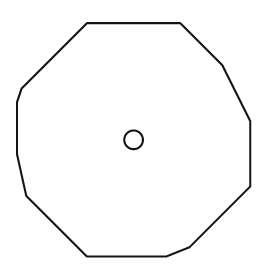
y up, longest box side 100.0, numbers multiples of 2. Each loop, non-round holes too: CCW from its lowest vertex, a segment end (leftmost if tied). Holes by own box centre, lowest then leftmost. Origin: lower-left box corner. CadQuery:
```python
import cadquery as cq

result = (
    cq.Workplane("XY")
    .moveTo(30.0, 0.0)
    .lineTo(64.0, 0.0)
    .lineTo(74.0, 4.0)
    .lineTo(100.0, 30.0)
    .lineTo(100.0, 58.0)
    .lineTo(88.0, 82.0)
    .lineTo(70.0, 100.0)
    .lineTo(30.0, 100.0)
    .lineTo(2.0, 72.0)
    .lineTo(0.0, 66.0)
    .lineTo(0.0, 44.0)
    .lineTo(4.0, 26.0)
    .close()
    .moveTo(50.0, 50.0)
    .circle(4.0)
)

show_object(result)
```